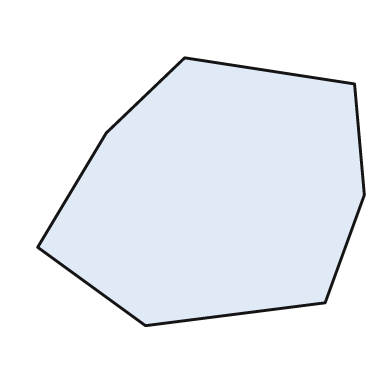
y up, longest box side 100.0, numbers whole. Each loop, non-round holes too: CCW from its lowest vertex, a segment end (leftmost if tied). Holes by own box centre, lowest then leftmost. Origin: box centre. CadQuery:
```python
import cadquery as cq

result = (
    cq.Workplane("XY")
    .moveTo(-17.0, -41.0)
    .lineTo(38.0, -34.0)
    .lineTo(50.0, -1.0)
    .lineTo(47.0, 33.0)
    .lineTo(-5.0, 41.0)
    .lineTo(-29.0, 18.0)
    .lineTo(-50.0, -17.0)
    .close()
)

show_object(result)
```